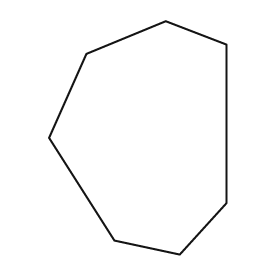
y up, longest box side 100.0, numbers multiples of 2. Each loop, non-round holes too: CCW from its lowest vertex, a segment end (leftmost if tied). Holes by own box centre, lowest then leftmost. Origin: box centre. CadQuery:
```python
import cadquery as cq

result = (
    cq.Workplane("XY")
    .moveTo(18.0, -50.0)
    .lineTo(38.0, -28.0)
    .lineTo(38.0, 40.0)
    .lineTo(12.0, 50.0)
    .lineTo(-22.0, 36.0)
    .lineTo(-38.0, 0.0)
    .lineTo(-10.0, -44.0)
    .close()
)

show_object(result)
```